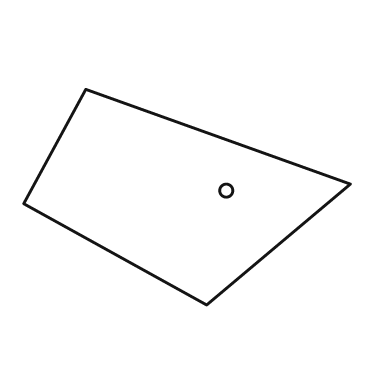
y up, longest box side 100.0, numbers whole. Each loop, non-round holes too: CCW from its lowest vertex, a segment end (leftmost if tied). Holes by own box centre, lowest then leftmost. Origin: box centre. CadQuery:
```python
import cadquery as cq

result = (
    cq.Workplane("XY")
    .moveTo(6.0, -33.0)
    .lineTo(50.0, 4.0)
    .lineTo(-31.0, 33.0)
    .lineTo(-50.0, -2.0)
    .close()
    .moveTo(12.0, 2.0)
    .circle(2.0)
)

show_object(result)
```